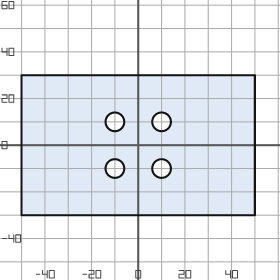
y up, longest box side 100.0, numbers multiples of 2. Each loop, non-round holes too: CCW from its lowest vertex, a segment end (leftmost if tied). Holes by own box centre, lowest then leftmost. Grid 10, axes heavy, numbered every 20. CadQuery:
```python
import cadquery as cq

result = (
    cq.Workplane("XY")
    .moveTo(-50.0, -30.0)
    .lineTo(50.0, -30.0)
    .lineTo(50.0, 30.0)
    .lineTo(-50.0, 30.0)
    .close()
    .moveTo(-10.0, -10.0)
    .circle(4.0)
    .moveTo(10.0, -10.0)
    .circle(4.0)
    .moveTo(-10.0, 10.0)
    .circle(4.0)
    .moveTo(10.0, 10.0)
    .circle(4.0)
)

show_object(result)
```